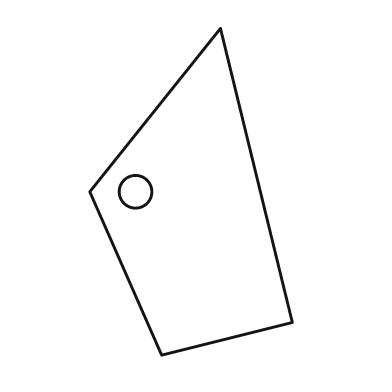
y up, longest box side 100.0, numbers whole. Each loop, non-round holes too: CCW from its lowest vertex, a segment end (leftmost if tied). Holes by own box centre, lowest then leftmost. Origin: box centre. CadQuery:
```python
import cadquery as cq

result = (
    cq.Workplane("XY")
    .moveTo(-9.0, -50.0)
    .lineTo(31.0, -40.0)
    .lineTo(9.0, 50.0)
    .lineTo(-31.0, 0.0)
    .close()
    .moveTo(-17.0, 0.0)
    .circle(5.0)
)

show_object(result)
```